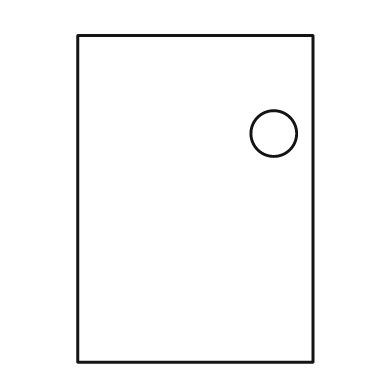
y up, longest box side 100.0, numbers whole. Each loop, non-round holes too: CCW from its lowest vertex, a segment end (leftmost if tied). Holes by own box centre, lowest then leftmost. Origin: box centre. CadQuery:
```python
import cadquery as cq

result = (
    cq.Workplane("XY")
    .moveTo(-36.0, -50.0)
    .lineTo(36.0, -50.0)
    .lineTo(36.0, 50.0)
    .lineTo(-36.0, 50.0)
    .close()
    .moveTo(24.0, 20.0)
    .circle(7.0)
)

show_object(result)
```